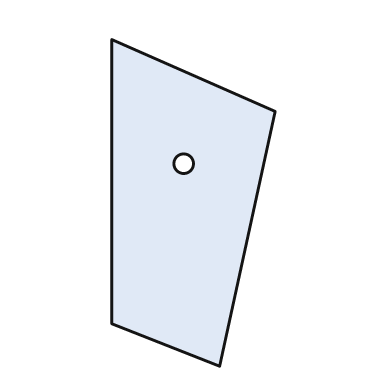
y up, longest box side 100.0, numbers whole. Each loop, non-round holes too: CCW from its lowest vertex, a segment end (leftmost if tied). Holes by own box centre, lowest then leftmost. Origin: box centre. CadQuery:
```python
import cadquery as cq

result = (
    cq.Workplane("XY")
    .moveTo(8.0, -50.0)
    .lineTo(25.0, 28.0)
    .lineTo(-25.0, 50.0)
    .lineTo(-25.0, -37.0)
    .close()
    .moveTo(-3.0, 12.0)
    .circle(3.0)
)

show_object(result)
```